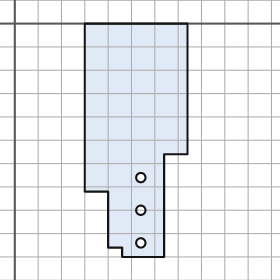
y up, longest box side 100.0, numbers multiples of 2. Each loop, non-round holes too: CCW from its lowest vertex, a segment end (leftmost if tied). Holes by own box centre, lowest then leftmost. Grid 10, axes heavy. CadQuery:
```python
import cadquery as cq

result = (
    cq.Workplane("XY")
    .moveTo(46.0, -100.0)
    .lineTo(64.0, -100.0)
    .lineTo(64.0, -56.0)
    .lineTo(74.0, -56.0)
    .lineTo(74.0, 0.0)
    .lineTo(30.0, 0.0)
    .lineTo(30.0, -72.0)
    .lineTo(40.0, -72.0)
    .lineTo(40.0, -96.0)
    .lineTo(46.0, -96.0)
    .close()
    .moveTo(54.0, -94.0)
    .circle(2.0)
    .moveTo(54.0, -80.0)
    .circle(2.0)
    .moveTo(54.0, -66.0)
    .circle(2.0)
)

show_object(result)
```